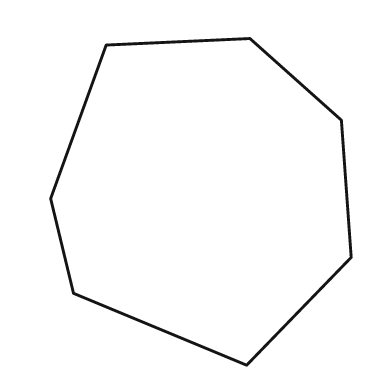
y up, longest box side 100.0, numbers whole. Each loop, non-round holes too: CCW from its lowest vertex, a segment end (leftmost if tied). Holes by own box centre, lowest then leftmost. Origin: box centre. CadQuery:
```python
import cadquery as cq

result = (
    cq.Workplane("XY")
    .moveTo(14.0, -50.0)
    .lineTo(46.0, -17.0)
    .lineTo(43.0, 25.0)
    .lineTo(15.0, 50.0)
    .lineTo(-29.0, 48.0)
    .lineTo(-46.0, 1.0)
    .lineTo(-39.0, -28.0)
    .close()
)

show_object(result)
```